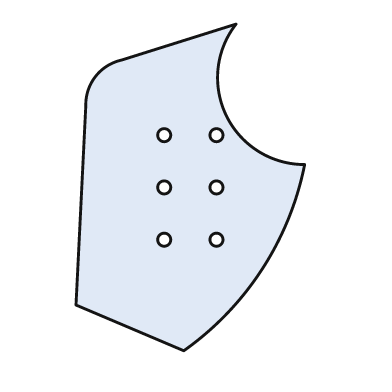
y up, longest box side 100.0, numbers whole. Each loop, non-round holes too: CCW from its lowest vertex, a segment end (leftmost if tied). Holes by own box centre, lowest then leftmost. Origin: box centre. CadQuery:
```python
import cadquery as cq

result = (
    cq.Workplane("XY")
    .moveTo(-2.0, -50.0)
    .threePointArc((22.0, -25.0), (35.0, 7.0))
    .threePointArc((11.0, 22.0), (14.0, 50.0))
    .lineTo(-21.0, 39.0)
    .threePointArc((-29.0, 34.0), (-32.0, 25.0))
    .lineTo(-35.0, -36.0)
    .close()
    .moveTo(-8.0, -16.0)
    .circle(2.0)
    .moveTo(8.0, -16.0)
    .circle(2.0)
    .moveTo(-8.0, 0.0)
    .circle(2.0)
    .moveTo(8.0, 0.0)
    .circle(2.0)
    .moveTo(-8.0, 16.0)
    .circle(2.0)
    .moveTo(8.0, 16.0)
    .circle(2.0)
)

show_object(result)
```